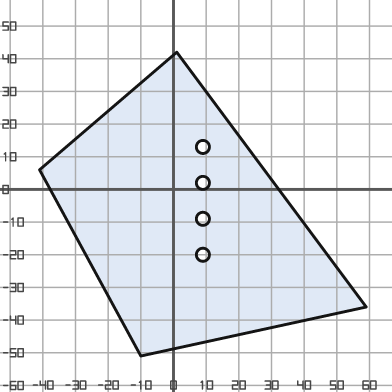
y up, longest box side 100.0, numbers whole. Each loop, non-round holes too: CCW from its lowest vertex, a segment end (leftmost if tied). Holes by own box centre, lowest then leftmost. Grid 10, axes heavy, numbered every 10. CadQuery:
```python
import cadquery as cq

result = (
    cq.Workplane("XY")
    .moveTo(-10.0, -51.0)
    .lineTo(59.0, -36.0)
    .lineTo(1.0, 42.0)
    .lineTo(-41.0, 6.0)
    .close()
    .moveTo(9.0, -20.0)
    .circle(2.0)
    .moveTo(9.0, -9.0)
    .circle(2.0)
    .moveTo(9.0, 2.0)
    .circle(2.0)
    .moveTo(9.0, 13.0)
    .circle(2.0)
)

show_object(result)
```